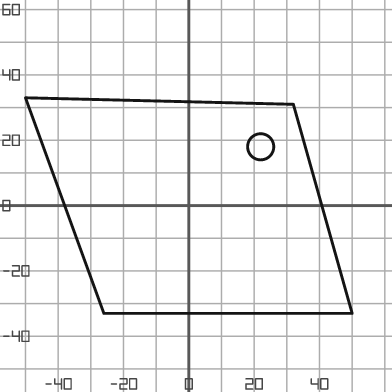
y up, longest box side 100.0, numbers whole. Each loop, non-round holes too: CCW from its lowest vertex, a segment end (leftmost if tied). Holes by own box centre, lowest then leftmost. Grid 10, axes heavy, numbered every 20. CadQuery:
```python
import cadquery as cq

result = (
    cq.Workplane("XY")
    .moveTo(-26.0, -33.0)
    .lineTo(50.0, -33.0)
    .lineTo(32.0, 31.0)
    .lineTo(-50.0, 33.0)
    .close()
    .moveTo(22.0, 18.0)
    .circle(4.0)
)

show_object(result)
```